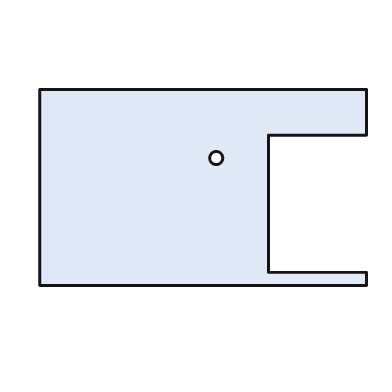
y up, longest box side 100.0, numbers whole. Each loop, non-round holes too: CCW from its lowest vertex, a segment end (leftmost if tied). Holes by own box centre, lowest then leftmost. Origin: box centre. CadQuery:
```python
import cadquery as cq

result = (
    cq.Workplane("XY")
    .moveTo(-50.0, -30.0)
    .lineTo(50.0, -30.0)
    .lineTo(50.0, -26.0)
    .lineTo(20.0, -26.0)
    .lineTo(20.0, 16.0)
    .lineTo(50.0, 16.0)
    .lineTo(50.0, 30.0)
    .lineTo(-50.0, 30.0)
    .close()
    .moveTo(4.0, 9.0)
    .circle(2.0)
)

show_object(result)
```